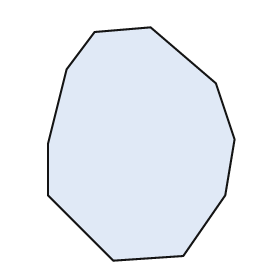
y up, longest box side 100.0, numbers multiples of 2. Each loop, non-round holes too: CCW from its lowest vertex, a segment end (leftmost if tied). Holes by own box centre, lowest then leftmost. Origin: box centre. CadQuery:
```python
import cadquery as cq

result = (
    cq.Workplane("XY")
    .moveTo(-12.0, -50.0)
    .lineTo(18.0, -48.0)
    .lineTo(36.0, -22.0)
    .lineTo(40.0, 2.0)
    .lineTo(32.0, 26.0)
    .lineTo(4.0, 50.0)
    .lineTo(-20.0, 48.0)
    .lineTo(-32.0, 32.0)
    .lineTo(-40.0, 0.0)
    .lineTo(-40.0, -22.0)
    .close()
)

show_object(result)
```